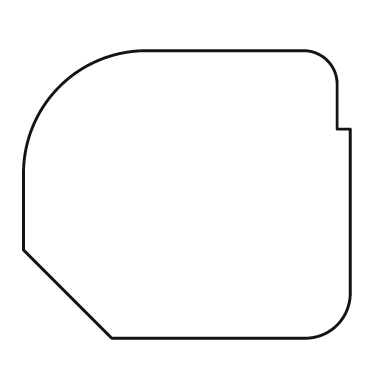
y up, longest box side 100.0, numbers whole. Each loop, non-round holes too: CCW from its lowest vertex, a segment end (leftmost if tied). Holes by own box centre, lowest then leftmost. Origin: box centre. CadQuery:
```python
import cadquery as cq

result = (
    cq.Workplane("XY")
    .moveTo(-23.0, -44.0)
    .lineTo(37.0, -44.0)
    .threePointArc((46.0, -40.0), (50.0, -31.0))
    .lineTo(50.0, 20.0)
    .lineTo(46.0, 20.0)
    .lineTo(46.0, 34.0)
    .threePointArc((43.0, 41.0), (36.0, 44.0))
    .lineTo(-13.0, 44.0)
    .threePointArc((-39.0, 33.0), (-50.0, 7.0))
    .lineTo(-50.0, -17.0)
    .close()
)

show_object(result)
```